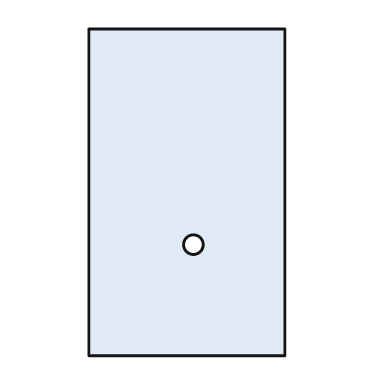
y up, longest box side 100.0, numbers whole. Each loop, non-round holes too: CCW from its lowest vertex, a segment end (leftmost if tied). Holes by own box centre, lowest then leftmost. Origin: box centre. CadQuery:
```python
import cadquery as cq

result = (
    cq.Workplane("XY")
    .moveTo(-30.0, -50.0)
    .lineTo(30.0, -50.0)
    .lineTo(30.0, 50.0)
    .lineTo(-30.0, 50.0)
    .close()
    .moveTo(2.0, -16.0)
    .circle(3.0)
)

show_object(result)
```